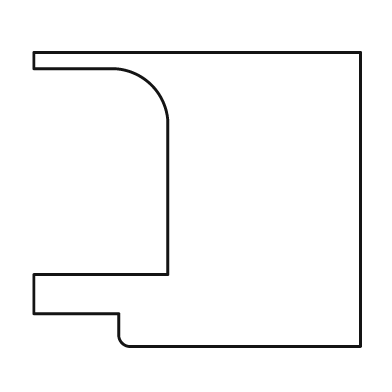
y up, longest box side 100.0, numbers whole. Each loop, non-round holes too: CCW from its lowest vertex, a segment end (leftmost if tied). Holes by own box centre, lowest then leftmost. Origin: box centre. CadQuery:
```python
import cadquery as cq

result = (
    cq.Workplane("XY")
    .moveTo(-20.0, -45.0)
    .lineTo(50.0, -45.0)
    .lineTo(50.0, 45.0)
    .lineTo(-50.0, 45.0)
    .lineTo(-50.0, 40.0)
    .lineTo(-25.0, 40.0)
    .threePointArc((-14.0, 35.0), (-9.0, 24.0))
    .lineTo(-9.0, -23.0)
    .lineTo(-50.0, -23.0)
    .lineTo(-50.0, -35.0)
    .lineTo(-24.0, -35.0)
    .lineTo(-24.0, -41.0)
    .threePointArc((-23.0, -44.0), (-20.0, -45.0))
    .close()
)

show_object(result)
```